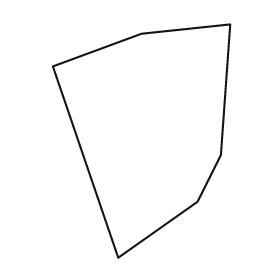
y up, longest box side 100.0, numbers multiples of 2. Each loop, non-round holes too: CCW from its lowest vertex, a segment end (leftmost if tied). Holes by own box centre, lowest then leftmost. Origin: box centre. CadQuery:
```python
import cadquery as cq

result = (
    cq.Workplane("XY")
    .moveTo(-10.0, -50.0)
    .lineTo(24.0, -26.0)
    .lineTo(34.0, -6.0)
    .lineTo(38.0, 50.0)
    .lineTo(0.0, 46.0)
    .lineTo(-38.0, 32.0)
    .close()
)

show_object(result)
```